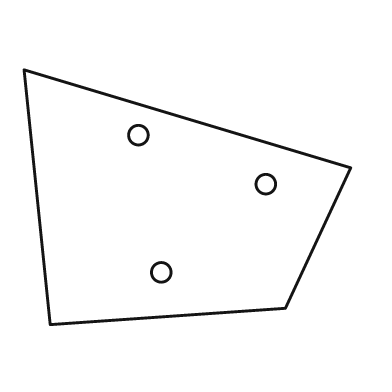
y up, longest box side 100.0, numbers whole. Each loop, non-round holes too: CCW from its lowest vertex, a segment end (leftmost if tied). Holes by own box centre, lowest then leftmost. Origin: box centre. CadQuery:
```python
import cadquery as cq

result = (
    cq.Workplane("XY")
    .moveTo(-42.0, -39.0)
    .lineTo(30.0, -34.0)
    .lineTo(50.0, 9.0)
    .lineTo(-50.0, 39.0)
    .close()
    .moveTo(-8.0, -23.0)
    .circle(3.0)
    .moveTo(24.0, 4.0)
    .circle(3.0)
    .moveTo(-15.0, 19.0)
    .circle(3.0)
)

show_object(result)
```